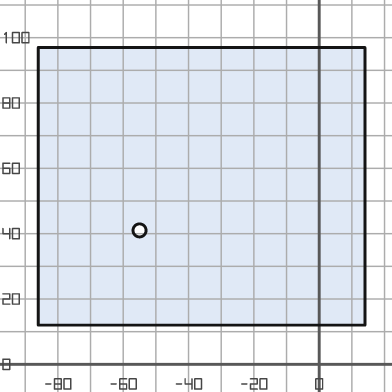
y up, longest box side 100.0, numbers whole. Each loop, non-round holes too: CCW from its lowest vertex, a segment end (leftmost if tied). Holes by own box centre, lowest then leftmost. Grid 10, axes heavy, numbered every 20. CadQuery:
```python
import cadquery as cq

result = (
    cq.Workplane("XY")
    .moveTo(-86.0, 12.0)
    .lineTo(14.0, 12.0)
    .lineTo(14.0, 97.0)
    .lineTo(-86.0, 97.0)
    .close()
    .moveTo(-55.0, 41.0)
    .circle(2.0)
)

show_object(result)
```